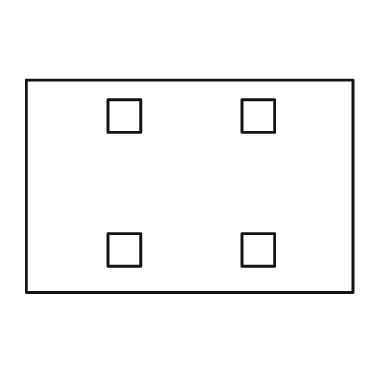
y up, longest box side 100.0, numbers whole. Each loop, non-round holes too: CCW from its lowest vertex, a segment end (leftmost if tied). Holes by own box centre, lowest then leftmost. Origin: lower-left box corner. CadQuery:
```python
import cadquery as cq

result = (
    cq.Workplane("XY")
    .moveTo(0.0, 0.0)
    .lineTo(100.0, 0.0)
    .lineTo(100.0, 65.0)
    .lineTo(0.0, 65.0)
    .close()
    .moveTo(25.0, 8.0)
    .lineTo(35.0, 8.0)
    .lineTo(35.0, 18.0)
    .lineTo(25.0, 18.0)
    .close()
    .moveTo(66.0, 8.0)
    .lineTo(76.0, 8.0)
    .lineTo(76.0, 18.0)
    .lineTo(66.0, 18.0)
    .close()
    .moveTo(25.0, 49.0)
    .lineTo(35.0, 49.0)
    .lineTo(35.0, 59.0)
    .lineTo(25.0, 59.0)
    .close()
    .moveTo(66.0, 49.0)
    .lineTo(76.0, 49.0)
    .lineTo(76.0, 59.0)
    .lineTo(66.0, 59.0)
    .close()
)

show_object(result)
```